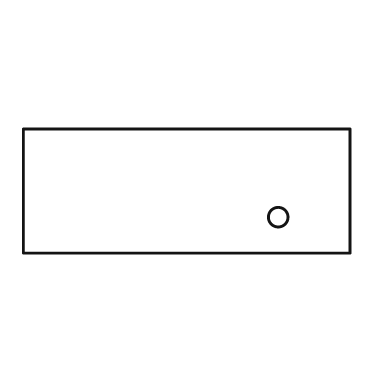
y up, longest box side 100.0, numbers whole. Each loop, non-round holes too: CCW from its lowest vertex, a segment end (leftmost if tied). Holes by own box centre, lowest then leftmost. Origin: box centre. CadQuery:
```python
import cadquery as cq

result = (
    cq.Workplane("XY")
    .moveTo(-50.0, -19.0)
    .lineTo(50.0, -19.0)
    .lineTo(50.0, 19.0)
    .lineTo(-50.0, 19.0)
    .close()
    .moveTo(28.0, -8.0)
    .circle(3.0)
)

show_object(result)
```